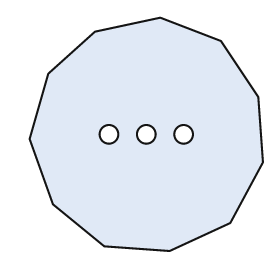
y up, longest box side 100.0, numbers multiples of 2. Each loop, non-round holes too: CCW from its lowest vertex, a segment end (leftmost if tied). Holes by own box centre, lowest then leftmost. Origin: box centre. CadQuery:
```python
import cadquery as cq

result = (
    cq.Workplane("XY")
    .moveTo(10.0, -50.0)
    .lineTo(36.0, -38.0)
    .lineTo(50.0, -12.0)
    .lineTo(48.0, 16.0)
    .lineTo(32.0, 40.0)
    .lineTo(6.0, 50.0)
    .lineTo(-22.0, 44.0)
    .lineTo(-42.0, 26.0)
    .lineTo(-50.0, -2.0)
    .lineTo(-40.0, -30.0)
    .lineTo(-18.0, -48.0)
    .close()
    .moveTo(-16.0, 0.0)
    .circle(4.0)
    .moveTo(0.0, 0.0)
    .circle(4.0)
    .moveTo(16.0, 0.0)
    .circle(4.0)
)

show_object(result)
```